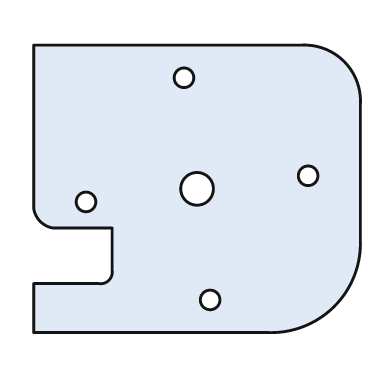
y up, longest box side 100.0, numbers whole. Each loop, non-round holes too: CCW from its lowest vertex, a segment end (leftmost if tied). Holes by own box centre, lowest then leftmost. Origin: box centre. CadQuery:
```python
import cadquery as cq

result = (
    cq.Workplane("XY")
    .moveTo(-50.0, -44.0)
    .lineTo(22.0, -44.0)
    .threePointArc((42.0, -36.0), (50.0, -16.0))
    .lineTo(50.0, 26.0)
    .threePointArc((45.0, 39.0), (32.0, 44.0))
    .lineTo(-50.0, 44.0)
    .lineTo(-50.0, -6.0)
    .threePointArc((-48.0, -10.0), (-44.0, -12.0))
    .lineTo(-26.0, -12.0)
    .lineTo(-26.0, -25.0)
    .threePointArc((-27.0, -28.0), (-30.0, -29.0))
    .lineTo(-50.0, -29.0)
    .close()
    .moveTo(4.0, -34.0)
    .circle(3.0)
    .moveTo(-34.0, -4.0)
    .circle(3.0)
    .moveTo(0.0, 0.0)
    .circle(5.0)
    .moveTo(34.0, 4.0)
    .circle(3.0)
    .moveTo(-4.0, 34.0)
    .circle(3.0)
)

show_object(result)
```